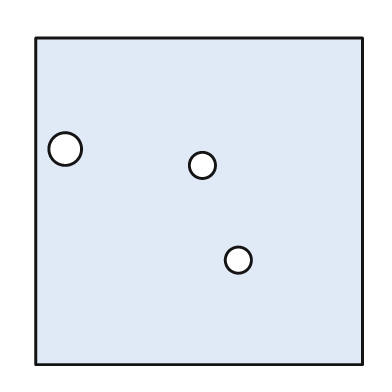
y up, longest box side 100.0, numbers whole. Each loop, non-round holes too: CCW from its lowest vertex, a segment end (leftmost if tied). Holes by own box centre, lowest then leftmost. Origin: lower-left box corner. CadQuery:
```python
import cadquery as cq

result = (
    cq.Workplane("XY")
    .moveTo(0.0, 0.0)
    .lineTo(100.0, 0.0)
    .lineTo(100.0, 100.0)
    .lineTo(0.0, 100.0)
    .close()
    .moveTo(62.0, 32.0)
    .circle(4.0)
    .moveTo(51.0, 61.0)
    .circle(4.0)
    .moveTo(9.0, 66.0)
    .circle(5.0)
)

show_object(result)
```